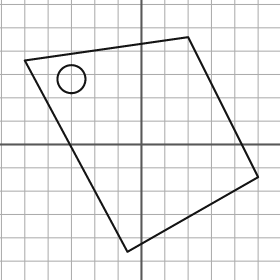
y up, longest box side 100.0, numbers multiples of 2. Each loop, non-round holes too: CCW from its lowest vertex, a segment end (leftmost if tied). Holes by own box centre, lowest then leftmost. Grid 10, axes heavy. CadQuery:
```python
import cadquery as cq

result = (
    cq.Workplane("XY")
    .moveTo(-6.0, -46.0)
    .lineTo(50.0, -14.0)
    .lineTo(20.0, 46.0)
    .lineTo(-50.0, 36.0)
    .close()
    .moveTo(-30.0, 28.0)
    .circle(6.0)
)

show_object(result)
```